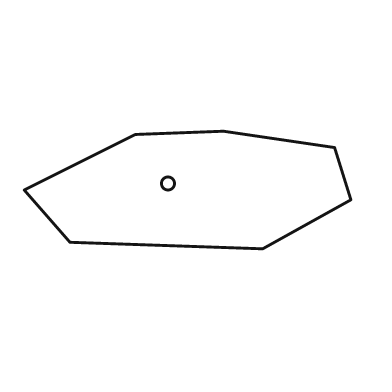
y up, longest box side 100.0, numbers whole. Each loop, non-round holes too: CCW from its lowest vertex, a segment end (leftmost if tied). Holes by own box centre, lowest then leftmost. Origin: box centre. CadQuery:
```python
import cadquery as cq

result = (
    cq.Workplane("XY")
    .moveTo(23.0, -18.0)
    .lineTo(50.0, -3.0)
    .lineTo(45.0, 13.0)
    .lineTo(11.0, 18.0)
    .lineTo(-16.0, 17.0)
    .lineTo(-50.0, 0.0)
    .lineTo(-36.0, -16.0)
    .close()
    .moveTo(-6.0, 2.0)
    .circle(2.0)
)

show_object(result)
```